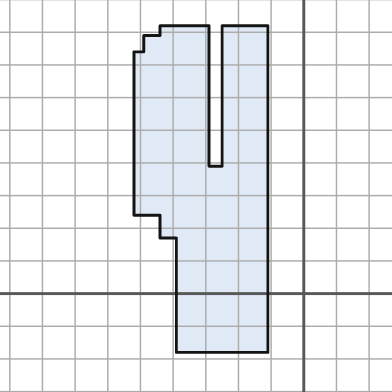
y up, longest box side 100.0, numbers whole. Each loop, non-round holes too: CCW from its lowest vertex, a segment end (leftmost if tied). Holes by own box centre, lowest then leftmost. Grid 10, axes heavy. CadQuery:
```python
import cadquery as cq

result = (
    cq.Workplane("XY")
    .moveTo(-39.0, -18.0)
    .lineTo(-11.0, -18.0)
    .lineTo(-11.0, 82.0)
    .lineTo(-25.0, 82.0)
    .lineTo(-25.0, 39.0)
    .lineTo(-29.0, 39.0)
    .lineTo(-29.0, 82.0)
    .lineTo(-44.0, 82.0)
    .lineTo(-44.0, 79.0)
    .lineTo(-49.0, 79.0)
    .lineTo(-49.0, 74.0)
    .lineTo(-52.0, 74.0)
    .lineTo(-52.0, 24.0)
    .lineTo(-44.0, 24.0)
    .lineTo(-44.0, 17.0)
    .lineTo(-39.0, 17.0)
    .close()
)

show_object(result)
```